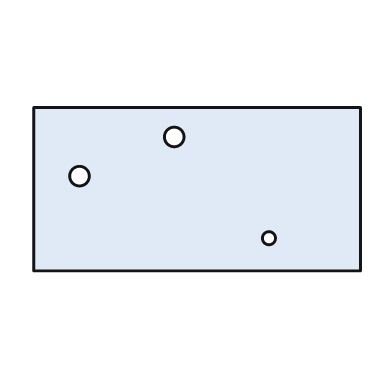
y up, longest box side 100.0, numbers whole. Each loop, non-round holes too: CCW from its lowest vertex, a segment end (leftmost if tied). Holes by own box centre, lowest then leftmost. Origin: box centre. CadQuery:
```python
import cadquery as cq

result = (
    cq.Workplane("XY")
    .moveTo(-50.0, -25.0)
    .lineTo(50.0, -25.0)
    .lineTo(50.0, 25.0)
    .lineTo(-50.0, 25.0)
    .close()
    .moveTo(22.0, -15.0)
    .circle(2.0)
    .moveTo(-36.0, 4.0)
    .circle(3.0)
    .moveTo(-7.0, 16.0)
    .circle(3.0)
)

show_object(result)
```